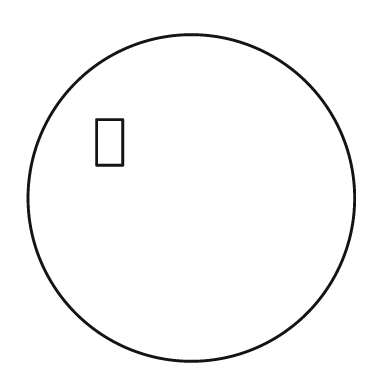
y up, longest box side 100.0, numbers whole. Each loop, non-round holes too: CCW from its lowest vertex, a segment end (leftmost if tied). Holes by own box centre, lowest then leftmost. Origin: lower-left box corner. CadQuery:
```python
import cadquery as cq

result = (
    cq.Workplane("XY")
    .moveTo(50.0, 50.0)
    .circle(50.0)
    .moveTo(21.0, 60.0)
    .lineTo(29.0, 60.0)
    .lineTo(29.0, 74.0)
    .lineTo(21.0, 74.0)
    .close()
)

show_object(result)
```